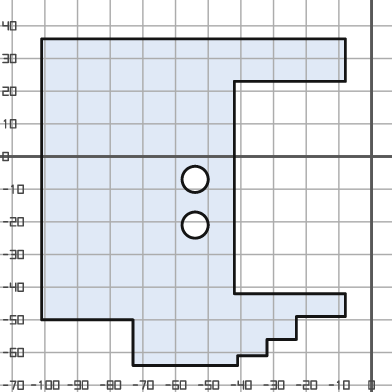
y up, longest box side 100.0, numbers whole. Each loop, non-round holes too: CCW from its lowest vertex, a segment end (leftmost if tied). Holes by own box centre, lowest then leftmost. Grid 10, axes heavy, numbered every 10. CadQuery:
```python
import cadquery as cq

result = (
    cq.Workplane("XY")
    .moveTo(-73.0, -64.0)
    .lineTo(-41.0, -64.0)
    .lineTo(-41.0, -61.0)
    .lineTo(-32.0, -61.0)
    .lineTo(-32.0, -56.0)
    .lineTo(-23.0, -56.0)
    .lineTo(-23.0, -49.0)
    .lineTo(-8.0, -49.0)
    .lineTo(-8.0, -42.0)
    .lineTo(-42.0, -42.0)
    .lineTo(-42.0, 23.0)
    .lineTo(-8.0, 23.0)
    .lineTo(-8.0, 36.0)
    .lineTo(-101.0, 36.0)
    .lineTo(-101.0, -50.0)
    .lineTo(-73.0, -50.0)
    .close()
    .moveTo(-54.0, -21.0)
    .circle(4.0)
    .moveTo(-54.0, -7.0)
    .circle(4.0)
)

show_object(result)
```